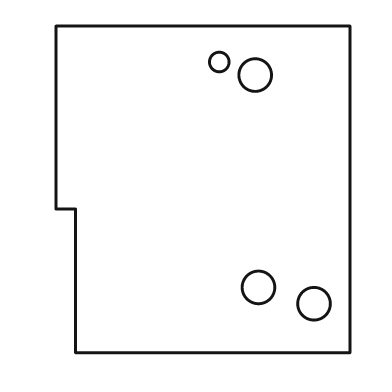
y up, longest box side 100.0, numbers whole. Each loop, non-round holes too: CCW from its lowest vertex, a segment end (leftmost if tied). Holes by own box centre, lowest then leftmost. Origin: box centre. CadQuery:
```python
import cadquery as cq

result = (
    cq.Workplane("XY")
    .moveTo(-39.0, -50.0)
    .lineTo(45.0, -50.0)
    .lineTo(45.0, 50.0)
    .lineTo(-45.0, 50.0)
    .lineTo(-45.0, -6.0)
    .lineTo(-39.0, -6.0)
    .close()
    .moveTo(34.0, -35.0)
    .circle(5.0)
    .moveTo(17.0, -30.0)
    .circle(5.0)
    .moveTo(16.0, 35.0)
    .circle(5.0)
    .moveTo(5.0, 39.0)
    .circle(3.0)
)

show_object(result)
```